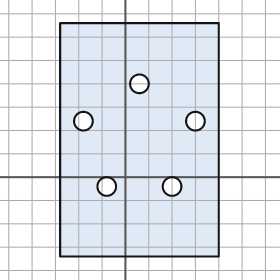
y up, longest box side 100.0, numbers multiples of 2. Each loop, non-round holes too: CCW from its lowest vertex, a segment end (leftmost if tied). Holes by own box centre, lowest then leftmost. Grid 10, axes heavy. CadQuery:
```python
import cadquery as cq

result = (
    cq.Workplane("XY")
    .moveTo(-28.0, -34.0)
    .lineTo(40.0, -34.0)
    .lineTo(40.0, 66.0)
    .lineTo(-28.0, 66.0)
    .close()
    .moveTo(-8.0, -4.0)
    .circle(4.0)
    .moveTo(20.0, -4.0)
    .circle(4.0)
    .moveTo(-18.0, 24.0)
    .circle(4.0)
    .moveTo(30.0, 24.0)
    .circle(4.0)
    .moveTo(6.0, 40.0)
    .circle(4.0)
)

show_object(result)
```